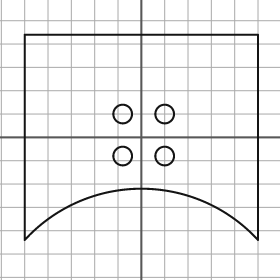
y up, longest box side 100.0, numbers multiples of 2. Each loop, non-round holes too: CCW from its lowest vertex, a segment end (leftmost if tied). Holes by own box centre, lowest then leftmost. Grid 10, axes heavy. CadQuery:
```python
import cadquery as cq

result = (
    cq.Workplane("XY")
    .moveTo(-50.0, -44.0)
    .threePointArc((0.0, -22.0), (50.0, -44.0))
    .lineTo(50.0, 44.0)
    .lineTo(-50.0, 44.0)
    .close()
    .moveTo(-8.0, -8.0)
    .circle(4.0)
    .moveTo(10.0, -8.0)
    .circle(4.0)
    .moveTo(-8.0, 10.0)
    .circle(4.0)
    .moveTo(10.0, 10.0)
    .circle(4.0)
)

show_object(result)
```